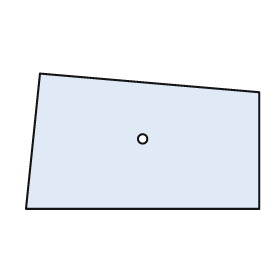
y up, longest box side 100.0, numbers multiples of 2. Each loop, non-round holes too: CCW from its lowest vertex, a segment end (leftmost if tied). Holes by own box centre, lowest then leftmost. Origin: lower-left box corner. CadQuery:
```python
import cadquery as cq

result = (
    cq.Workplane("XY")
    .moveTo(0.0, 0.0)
    .lineTo(100.0, 0.0)
    .lineTo(100.0, 50.0)
    .lineTo(6.0, 58.0)
    .close()
    .moveTo(50.0, 30.0)
    .circle(2.0)
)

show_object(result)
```